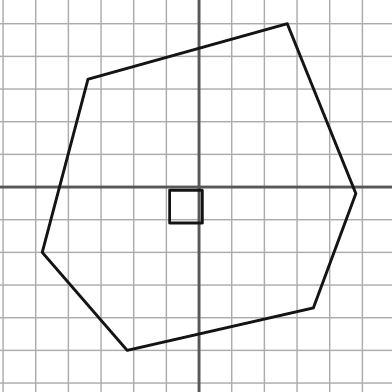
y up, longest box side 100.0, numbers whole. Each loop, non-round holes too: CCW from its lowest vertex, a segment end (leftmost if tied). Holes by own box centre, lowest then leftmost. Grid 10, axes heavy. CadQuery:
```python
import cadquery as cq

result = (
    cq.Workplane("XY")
    .moveTo(-22.0, -50.0)
    .lineTo(35.0, -37.0)
    .lineTo(48.0, -2.0)
    .lineTo(27.0, 50.0)
    .lineTo(-34.0, 33.0)
    .lineTo(-48.0, -20.0)
    .close()
    .moveTo(-9.0, -11.0)
    .lineTo(1.0, -11.0)
    .lineTo(1.0, -1.0)
    .lineTo(-9.0, -1.0)
    .close()
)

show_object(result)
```